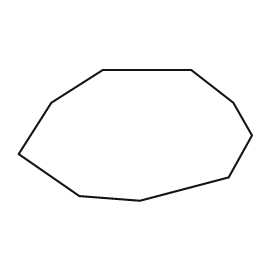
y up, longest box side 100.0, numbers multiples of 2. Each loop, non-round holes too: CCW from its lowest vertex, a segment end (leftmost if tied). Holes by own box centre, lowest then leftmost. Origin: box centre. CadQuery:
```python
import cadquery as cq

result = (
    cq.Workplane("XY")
    .moveTo(2.0, -28.0)
    .lineTo(40.0, -18.0)
    .lineTo(50.0, 0.0)
    .lineTo(42.0, 14.0)
    .lineTo(24.0, 28.0)
    .lineTo(-14.0, 28.0)
    .lineTo(-36.0, 14.0)
    .lineTo(-50.0, -8.0)
    .lineTo(-24.0, -26.0)
    .close()
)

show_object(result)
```